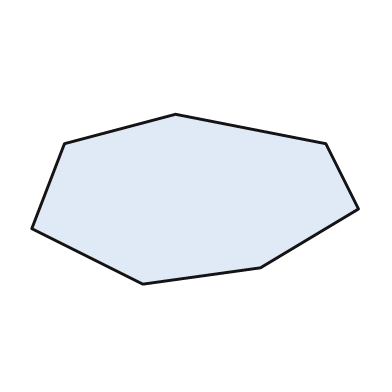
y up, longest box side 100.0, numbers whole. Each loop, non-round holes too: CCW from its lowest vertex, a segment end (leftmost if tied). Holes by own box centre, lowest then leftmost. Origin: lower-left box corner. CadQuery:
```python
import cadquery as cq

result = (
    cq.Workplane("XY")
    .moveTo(34.0, 0.0)
    .lineTo(70.0, 5.0)
    .lineTo(100.0, 23.0)
    .lineTo(90.0, 43.0)
    .lineTo(44.0, 52.0)
    .lineTo(10.0, 43.0)
    .lineTo(0.0, 17.0)
    .close()
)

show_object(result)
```